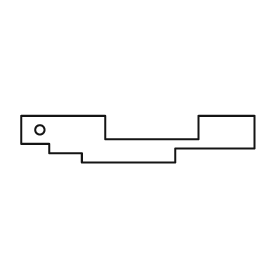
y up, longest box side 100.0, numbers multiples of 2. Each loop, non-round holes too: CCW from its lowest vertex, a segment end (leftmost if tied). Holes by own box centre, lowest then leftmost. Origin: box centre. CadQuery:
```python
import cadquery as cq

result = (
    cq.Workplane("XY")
    .moveTo(-24.0, -10.0)
    .lineTo(16.0, -10.0)
    .lineTo(16.0, -4.0)
    .lineTo(50.0, -4.0)
    .lineTo(50.0, 10.0)
    .lineTo(26.0, 10.0)
    .lineTo(26.0, 0.0)
    .lineTo(-14.0, 0.0)
    .lineTo(-14.0, 10.0)
    .lineTo(-50.0, 10.0)
    .lineTo(-50.0, -2.0)
    .lineTo(-38.0, -2.0)
    .lineTo(-38.0, -6.0)
    .lineTo(-24.0, -6.0)
    .close()
    .moveTo(-42.0, 4.0)
    .circle(2.0)
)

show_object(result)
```